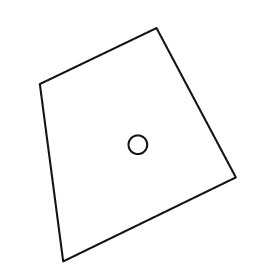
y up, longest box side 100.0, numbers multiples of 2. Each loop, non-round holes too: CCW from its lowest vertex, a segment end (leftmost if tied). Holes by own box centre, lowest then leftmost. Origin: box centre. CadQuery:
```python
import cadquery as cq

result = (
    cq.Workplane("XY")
    .moveTo(-32.0, -50.0)
    .lineTo(42.0, -14.0)
    .lineTo(8.0, 50.0)
    .lineTo(-42.0, 26.0)
    .close()
    .moveTo(0.0, 0.0)
    .circle(4.0)
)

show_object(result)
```